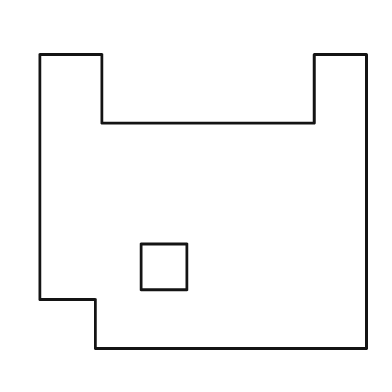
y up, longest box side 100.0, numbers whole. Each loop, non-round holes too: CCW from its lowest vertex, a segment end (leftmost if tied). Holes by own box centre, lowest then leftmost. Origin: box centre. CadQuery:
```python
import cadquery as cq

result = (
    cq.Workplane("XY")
    .moveTo(-33.0, -45.0)
    .lineTo(50.0, -45.0)
    .lineTo(50.0, 45.0)
    .lineTo(34.0, 45.0)
    .lineTo(34.0, 24.0)
    .lineTo(-31.0, 24.0)
    .lineTo(-31.0, 45.0)
    .lineTo(-50.0, 45.0)
    .lineTo(-50.0, -30.0)
    .lineTo(-33.0, -30.0)
    .close()
    .moveTo(-19.0, -27.0)
    .lineTo(-5.0, -27.0)
    .lineTo(-5.0, -13.0)
    .lineTo(-19.0, -13.0)
    .close()
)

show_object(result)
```